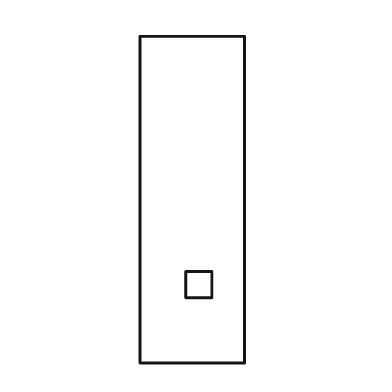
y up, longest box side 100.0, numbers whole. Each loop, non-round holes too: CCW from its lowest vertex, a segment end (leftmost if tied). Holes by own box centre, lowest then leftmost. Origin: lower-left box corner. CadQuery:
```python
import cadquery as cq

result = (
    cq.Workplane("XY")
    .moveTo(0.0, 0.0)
    .lineTo(32.0, 0.0)
    .lineTo(32.0, 100.0)
    .lineTo(0.0, 100.0)
    .close()
    .moveTo(14.0, 20.0)
    .lineTo(22.0, 20.0)
    .lineTo(22.0, 28.0)
    .lineTo(14.0, 28.0)
    .close()
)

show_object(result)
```